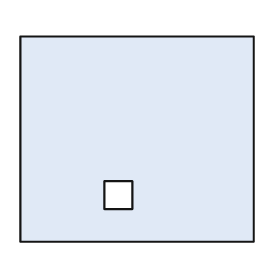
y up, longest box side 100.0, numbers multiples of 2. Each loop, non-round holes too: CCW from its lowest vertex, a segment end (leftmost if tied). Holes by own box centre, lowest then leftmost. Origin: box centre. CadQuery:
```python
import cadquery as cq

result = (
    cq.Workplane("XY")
    .moveTo(-50.0, -44.0)
    .lineTo(50.0, -44.0)
    .lineTo(50.0, 44.0)
    .lineTo(-50.0, 44.0)
    .close()
    .moveTo(-14.0, -30.0)
    .lineTo(-2.0, -30.0)
    .lineTo(-2.0, -18.0)
    .lineTo(-14.0, -18.0)
    .close()
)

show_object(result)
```